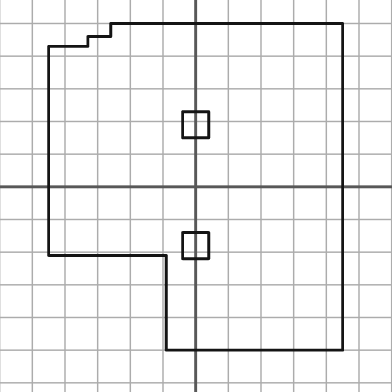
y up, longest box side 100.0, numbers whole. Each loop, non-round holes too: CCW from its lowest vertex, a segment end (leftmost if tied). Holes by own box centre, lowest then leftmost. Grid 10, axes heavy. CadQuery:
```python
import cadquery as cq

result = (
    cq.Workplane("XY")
    .moveTo(-9.0, -50.0)
    .lineTo(45.0, -50.0)
    .lineTo(45.0, 50.0)
    .lineTo(-26.0, 50.0)
    .lineTo(-26.0, 46.0)
    .lineTo(-33.0, 46.0)
    .lineTo(-33.0, 43.0)
    .lineTo(-45.0, 43.0)
    .lineTo(-45.0, -21.0)
    .lineTo(-9.0, -21.0)
    .close()
    .moveTo(-4.0, -22.0)
    .lineTo(4.0, -22.0)
    .lineTo(4.0, -14.0)
    .lineTo(-4.0, -14.0)
    .close()
    .moveTo(-4.0, 15.0)
    .lineTo(4.0, 15.0)
    .lineTo(4.0, 23.0)
    .lineTo(-4.0, 23.0)
    .close()
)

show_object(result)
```